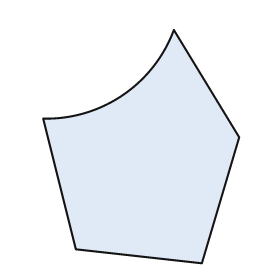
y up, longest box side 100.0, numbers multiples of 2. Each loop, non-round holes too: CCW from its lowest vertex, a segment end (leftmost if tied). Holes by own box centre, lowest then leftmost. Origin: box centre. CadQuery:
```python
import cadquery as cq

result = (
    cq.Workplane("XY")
    .moveTo(26.0, -50.0)
    .lineTo(42.0, 4.0)
    .lineTo(14.0, 50.0)
    .threePointArc((-8.0, 22.0), (-42.0, 12.0))
    .lineTo(-28.0, -44.0)
    .close()
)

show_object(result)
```